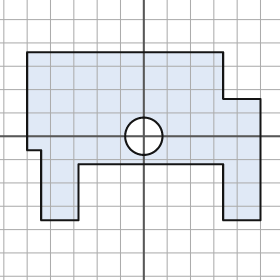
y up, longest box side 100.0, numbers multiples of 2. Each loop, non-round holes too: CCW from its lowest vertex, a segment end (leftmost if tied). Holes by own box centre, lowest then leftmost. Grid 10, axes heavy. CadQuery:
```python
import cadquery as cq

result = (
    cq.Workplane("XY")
    .moveTo(-44.0, -36.0)
    .lineTo(-28.0, -36.0)
    .lineTo(-28.0, -12.0)
    .lineTo(34.0, -12.0)
    .lineTo(34.0, -36.0)
    .lineTo(50.0, -36.0)
    .lineTo(50.0, 16.0)
    .lineTo(34.0, 16.0)
    .lineTo(34.0, 36.0)
    .lineTo(-50.0, 36.0)
    .lineTo(-50.0, -6.0)
    .lineTo(-44.0, -6.0)
    .close()
    .moveTo(0.0, 0.0)
    .circle(8.0)
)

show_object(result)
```